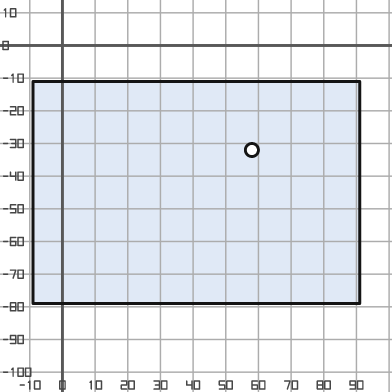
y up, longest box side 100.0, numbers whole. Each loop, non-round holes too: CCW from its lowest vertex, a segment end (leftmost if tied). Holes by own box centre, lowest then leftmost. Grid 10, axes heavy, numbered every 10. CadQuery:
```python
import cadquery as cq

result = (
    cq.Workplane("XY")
    .moveTo(-9.0, -79.0)
    .lineTo(91.0, -79.0)
    .lineTo(91.0, -11.0)
    .lineTo(-9.0, -11.0)
    .close()
    .moveTo(58.0, -32.0)
    .circle(2.0)
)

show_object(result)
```